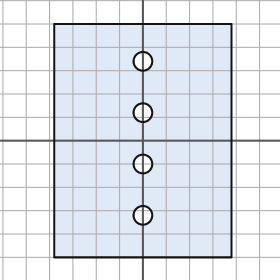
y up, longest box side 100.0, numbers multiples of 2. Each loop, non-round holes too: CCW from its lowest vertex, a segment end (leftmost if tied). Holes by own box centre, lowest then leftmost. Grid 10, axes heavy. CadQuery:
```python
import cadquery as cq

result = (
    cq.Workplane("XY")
    .moveTo(-38.0, -50.0)
    .lineTo(38.0, -50.0)
    .lineTo(38.0, 50.0)
    .lineTo(-38.0, 50.0)
    .close()
    .moveTo(0.0, -32.0)
    .circle(4.0)
    .moveTo(0.0, -10.0)
    .circle(4.0)
    .moveTo(0.0, 12.0)
    .circle(4.0)
    .moveTo(0.0, 34.0)
    .circle(4.0)
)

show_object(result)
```